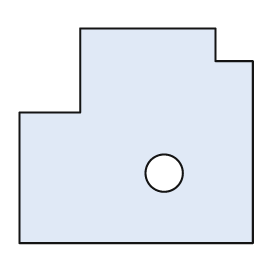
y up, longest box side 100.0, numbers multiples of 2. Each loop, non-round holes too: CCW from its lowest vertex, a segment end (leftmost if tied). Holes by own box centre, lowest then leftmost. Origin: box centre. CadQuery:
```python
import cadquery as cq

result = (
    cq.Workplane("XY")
    .moveTo(-50.0, -46.0)
    .lineTo(50.0, -46.0)
    .lineTo(50.0, 32.0)
    .lineTo(34.0, 32.0)
    .lineTo(34.0, 46.0)
    .lineTo(-24.0, 46.0)
    .lineTo(-24.0, 10.0)
    .lineTo(-50.0, 10.0)
    .close()
    .moveTo(12.0, -16.0)
    .circle(8.0)
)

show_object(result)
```